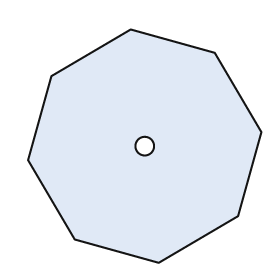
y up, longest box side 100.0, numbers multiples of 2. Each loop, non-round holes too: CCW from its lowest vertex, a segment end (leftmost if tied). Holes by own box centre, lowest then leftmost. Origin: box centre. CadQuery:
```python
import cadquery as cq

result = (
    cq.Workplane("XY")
    .moveTo(6.0, -50.0)
    .lineTo(40.0, -30.0)
    .lineTo(50.0, 6.0)
    .lineTo(30.0, 40.0)
    .lineTo(-6.0, 50.0)
    .lineTo(-40.0, 30.0)
    .lineTo(-50.0, -6.0)
    .lineTo(-30.0, -40.0)
    .close()
    .moveTo(0.0, 0.0)
    .circle(4.0)
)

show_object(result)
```